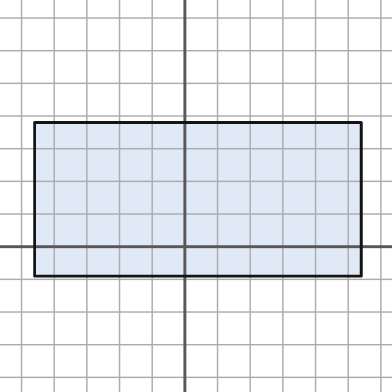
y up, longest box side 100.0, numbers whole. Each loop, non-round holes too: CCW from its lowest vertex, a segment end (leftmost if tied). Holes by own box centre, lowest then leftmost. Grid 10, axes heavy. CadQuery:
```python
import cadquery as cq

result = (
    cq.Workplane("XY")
    .moveTo(-46.0, -9.0)
    .lineTo(54.0, -9.0)
    .lineTo(54.0, 38.0)
    .lineTo(-46.0, 38.0)
    .close()
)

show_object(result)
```